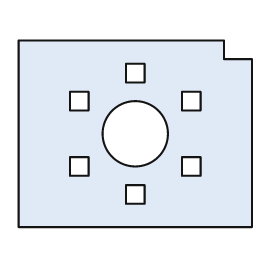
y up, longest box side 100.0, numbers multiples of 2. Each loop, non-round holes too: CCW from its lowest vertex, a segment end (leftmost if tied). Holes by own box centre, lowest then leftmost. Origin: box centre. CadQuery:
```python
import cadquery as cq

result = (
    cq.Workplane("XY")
    .moveTo(-50.0, -40.0)
    .lineTo(50.0, -40.0)
    .lineTo(50.0, 32.0)
    .lineTo(38.0, 32.0)
    .lineTo(38.0, 40.0)
    .lineTo(-50.0, 40.0)
    .close()
    .moveTo(-4.0, -30.0)
    .lineTo(4.0, -30.0)
    .lineTo(4.0, -22.0)
    .lineTo(-4.0, -22.0)
    .close()
    .moveTo(-28.0, -18.0)
    .lineTo(-20.0, -18.0)
    .lineTo(-20.0, -10.0)
    .lineTo(-28.0, -10.0)
    .close()
    .moveTo(20.0, -18.0)
    .lineTo(28.0, -18.0)
    .lineTo(28.0, -10.0)
    .lineTo(20.0, -10.0)
    .close()
    .moveTo(0.0, 0.0)
    .circle(14.0)
    .moveTo(-28.0, 10.0)
    .lineTo(-20.0, 10.0)
    .lineTo(-20.0, 18.0)
    .lineTo(-28.0, 18.0)
    .close()
    .moveTo(20.0, 10.0)
    .lineTo(28.0, 10.0)
    .lineTo(28.0, 18.0)
    .lineTo(20.0, 18.0)
    .close()
    .moveTo(-4.0, 22.0)
    .lineTo(4.0, 22.0)
    .lineTo(4.0, 30.0)
    .lineTo(-4.0, 30.0)
    .close()
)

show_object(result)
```